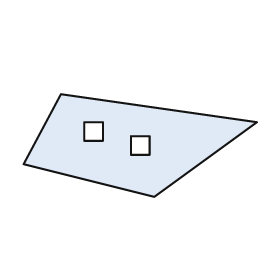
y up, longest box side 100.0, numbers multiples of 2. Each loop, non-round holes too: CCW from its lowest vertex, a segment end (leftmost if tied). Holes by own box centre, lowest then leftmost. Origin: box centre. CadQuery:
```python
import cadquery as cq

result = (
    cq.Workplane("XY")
    .moveTo(6.0, -22.0)
    .lineTo(50.0, 10.0)
    .lineTo(-34.0, 22.0)
    .lineTo(-50.0, -8.0)
    .close()
    .moveTo(-4.0, -4.0)
    .lineTo(4.0, -4.0)
    .lineTo(4.0, 4.0)
    .lineTo(-4.0, 4.0)
    .close()
    .moveTo(-24.0, 2.0)
    .lineTo(-16.0, 2.0)
    .lineTo(-16.0, 10.0)
    .lineTo(-24.0, 10.0)
    .close()
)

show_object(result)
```